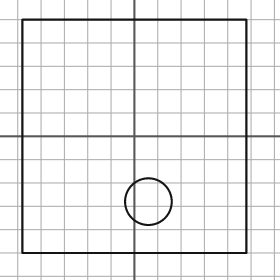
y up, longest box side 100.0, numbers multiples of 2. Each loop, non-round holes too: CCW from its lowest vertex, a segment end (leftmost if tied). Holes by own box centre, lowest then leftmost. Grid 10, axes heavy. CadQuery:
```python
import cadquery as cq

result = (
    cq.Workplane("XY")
    .moveTo(-48.0, -50.0)
    .lineTo(48.0, -50.0)
    .lineTo(48.0, 50.0)
    .lineTo(-48.0, 50.0)
    .close()
    .moveTo(6.0, -28.0)
    .circle(10.0)
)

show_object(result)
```